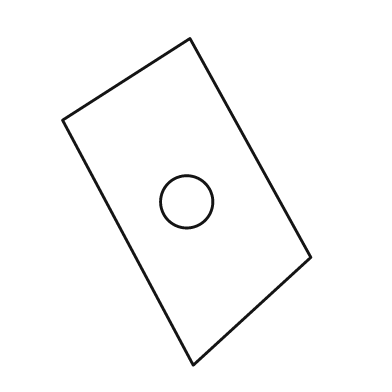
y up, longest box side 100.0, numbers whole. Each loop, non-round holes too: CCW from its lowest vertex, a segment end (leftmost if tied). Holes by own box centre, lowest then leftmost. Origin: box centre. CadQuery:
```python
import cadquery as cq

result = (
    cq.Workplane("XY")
    .moveTo(2.0, -50.0)
    .lineTo(38.0, -17.0)
    .lineTo(1.0, 50.0)
    .lineTo(-38.0, 25.0)
    .close()
    .moveTo(0.0, 0.0)
    .circle(8.0)
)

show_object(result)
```